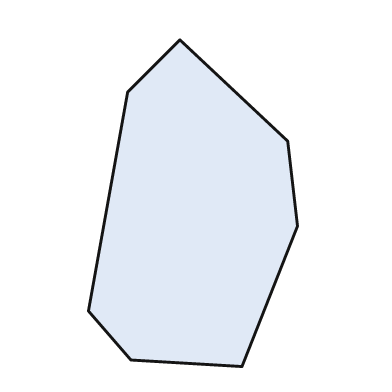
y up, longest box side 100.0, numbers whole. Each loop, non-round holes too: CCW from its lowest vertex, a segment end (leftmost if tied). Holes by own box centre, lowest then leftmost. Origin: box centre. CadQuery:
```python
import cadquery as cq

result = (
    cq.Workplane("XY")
    .moveTo(15.0, -50.0)
    .lineTo(32.0, -7.0)
    .lineTo(29.0, 19.0)
    .lineTo(-4.0, 50.0)
    .lineTo(-20.0, 34.0)
    .lineTo(-32.0, -33.0)
    .lineTo(-19.0, -48.0)
    .close()
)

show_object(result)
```